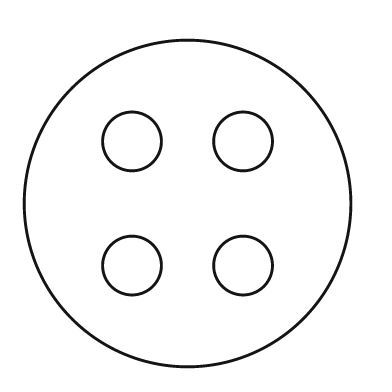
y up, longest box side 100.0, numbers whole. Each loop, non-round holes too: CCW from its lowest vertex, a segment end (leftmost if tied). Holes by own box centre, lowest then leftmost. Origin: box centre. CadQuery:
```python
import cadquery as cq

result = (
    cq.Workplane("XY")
    .moveTo(0.0, 0.0)
    .circle(50.0)
    .moveTo(-17.0, -19.0)
    .circle(9.0)
    .moveTo(17.0, -19.0)
    .circle(9.0)
    .moveTo(-17.0, 19.0)
    .circle(9.0)
    .moveTo(17.0, 19.0)
    .circle(9.0)
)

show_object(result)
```